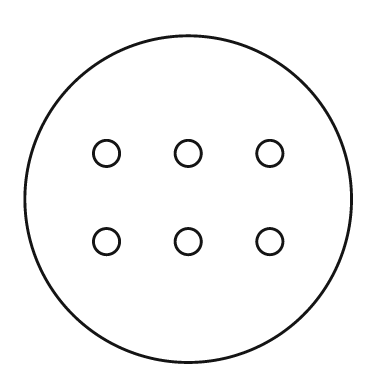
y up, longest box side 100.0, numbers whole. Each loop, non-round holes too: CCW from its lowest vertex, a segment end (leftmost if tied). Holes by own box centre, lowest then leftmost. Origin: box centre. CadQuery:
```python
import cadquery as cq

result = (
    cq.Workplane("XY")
    .moveTo(0.0, 0.0)
    .circle(50.0)
    .moveTo(-25.0, -13.0)
    .circle(4.0)
    .moveTo(0.0, -13.0)
    .circle(4.0)
    .moveTo(25.0, -13.0)
    .circle(4.0)
    .moveTo(-25.0, 14.0)
    .circle(4.0)
    .moveTo(0.0, 14.0)
    .circle(4.0)
    .moveTo(25.0, 14.0)
    .circle(4.0)
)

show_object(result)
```